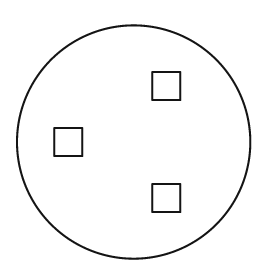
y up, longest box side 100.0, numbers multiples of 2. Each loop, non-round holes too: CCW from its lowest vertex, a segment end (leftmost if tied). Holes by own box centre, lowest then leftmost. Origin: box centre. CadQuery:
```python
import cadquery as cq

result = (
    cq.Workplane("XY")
    .moveTo(0.0, 0.0)
    .circle(50.0)
    .moveTo(8.0, -30.0)
    .lineTo(20.0, -30.0)
    .lineTo(20.0, -18.0)
    .lineTo(8.0, -18.0)
    .close()
    .moveTo(-34.0, -6.0)
    .lineTo(-22.0, -6.0)
    .lineTo(-22.0, 6.0)
    .lineTo(-34.0, 6.0)
    .close()
    .moveTo(8.0, 18.0)
    .lineTo(20.0, 18.0)
    .lineTo(20.0, 30.0)
    .lineTo(8.0, 30.0)
    .close()
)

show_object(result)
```